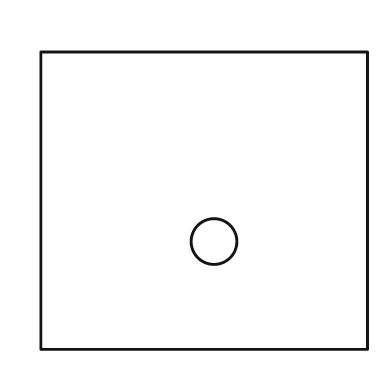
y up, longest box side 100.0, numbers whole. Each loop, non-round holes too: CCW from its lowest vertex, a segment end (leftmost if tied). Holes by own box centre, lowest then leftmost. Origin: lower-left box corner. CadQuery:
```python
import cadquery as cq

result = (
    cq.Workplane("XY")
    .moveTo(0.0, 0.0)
    .lineTo(100.0, 0.0)
    .lineTo(100.0, 91.0)
    .lineTo(0.0, 91.0)
    .close()
    .moveTo(53.0, 33.0)
    .circle(7.0)
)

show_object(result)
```